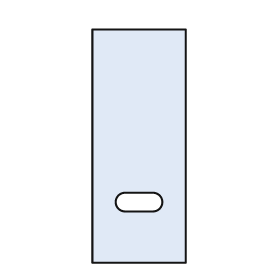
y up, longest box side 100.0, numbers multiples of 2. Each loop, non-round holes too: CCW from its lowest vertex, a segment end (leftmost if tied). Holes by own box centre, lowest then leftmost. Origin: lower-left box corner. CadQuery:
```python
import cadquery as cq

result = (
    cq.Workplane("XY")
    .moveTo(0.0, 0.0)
    .lineTo(40.0, 0.0)
    .lineTo(40.0, 100.0)
    .lineTo(0.0, 100.0)
    .close()
    .moveTo(14.0, 22.0)
    .lineTo(26.0, 22.0)
    .threePointArc((30.0, 26.0), (26.0, 30.0))
    .lineTo(14.0, 30.0)
    .threePointArc((10.0, 26.0), (14.0, 22.0))
    .close()
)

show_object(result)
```